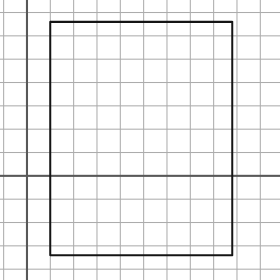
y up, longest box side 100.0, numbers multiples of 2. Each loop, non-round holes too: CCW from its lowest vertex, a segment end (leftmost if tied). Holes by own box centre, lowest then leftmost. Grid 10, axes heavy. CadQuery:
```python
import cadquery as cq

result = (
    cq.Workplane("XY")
    .moveTo(10.0, -34.0)
    .lineTo(88.0, -34.0)
    .lineTo(88.0, 66.0)
    .lineTo(10.0, 66.0)
    .close()
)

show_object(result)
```